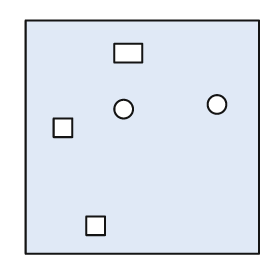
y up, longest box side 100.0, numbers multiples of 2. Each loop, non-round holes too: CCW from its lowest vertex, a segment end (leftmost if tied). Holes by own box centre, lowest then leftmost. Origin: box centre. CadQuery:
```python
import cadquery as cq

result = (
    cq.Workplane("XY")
    .moveTo(-50.0, -50.0)
    .lineTo(50.0, -50.0)
    .lineTo(50.0, 50.0)
    .lineTo(-50.0, 50.0)
    .close()
    .moveTo(-24.0, -42.0)
    .lineTo(-16.0, -42.0)
    .lineTo(-16.0, -34.0)
    .lineTo(-24.0, -34.0)
    .close()
    .moveTo(-38.0, 0.0)
    .lineTo(-30.0, 0.0)
    .lineTo(-30.0, 8.0)
    .lineTo(-38.0, 8.0)
    .close()
    .moveTo(-8.0, 12.0)
    .circle(4.0)
    .moveTo(32.0, 14.0)
    .circle(4.0)
    .moveTo(-12.0, 32.0)
    .lineTo(0.0, 32.0)
    .lineTo(0.0, 40.0)
    .lineTo(-12.0, 40.0)
    .close()
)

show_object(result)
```